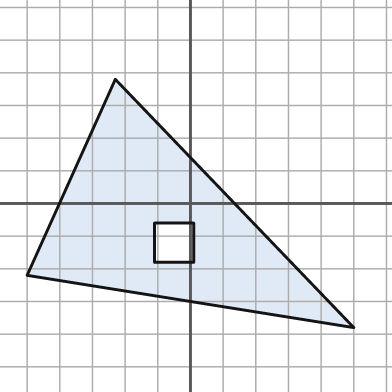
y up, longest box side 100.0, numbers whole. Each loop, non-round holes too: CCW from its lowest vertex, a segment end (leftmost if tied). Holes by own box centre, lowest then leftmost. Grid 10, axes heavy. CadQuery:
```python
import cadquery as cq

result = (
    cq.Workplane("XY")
    .moveTo(50.0, -38.0)
    .lineTo(-23.0, 38.0)
    .lineTo(-50.0, -22.0)
    .close()
    .moveTo(-11.0, -18.0)
    .lineTo(1.0, -18.0)
    .lineTo(1.0, -6.0)
    .lineTo(-11.0, -6.0)
    .close()
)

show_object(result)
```